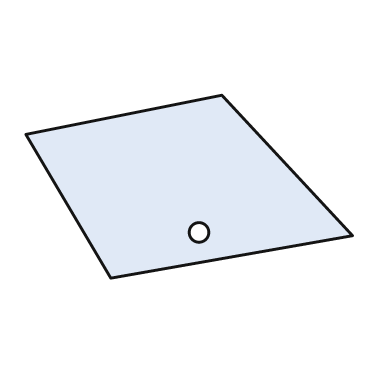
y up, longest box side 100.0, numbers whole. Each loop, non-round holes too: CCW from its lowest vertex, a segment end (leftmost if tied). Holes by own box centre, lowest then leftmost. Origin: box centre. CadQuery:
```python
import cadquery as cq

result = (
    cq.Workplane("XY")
    .moveTo(-24.0, -28.0)
    .lineTo(50.0, -15.0)
    .lineTo(10.0, 28.0)
    .lineTo(-50.0, 16.0)
    .close()
    .moveTo(3.0, -14.0)
    .circle(3.0)
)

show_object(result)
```